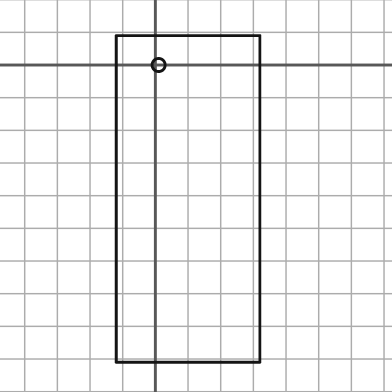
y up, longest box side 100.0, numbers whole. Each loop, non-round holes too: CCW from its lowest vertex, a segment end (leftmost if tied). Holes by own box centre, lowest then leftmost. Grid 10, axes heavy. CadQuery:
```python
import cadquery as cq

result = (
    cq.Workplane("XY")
    .moveTo(-12.0, -91.0)
    .lineTo(32.0, -91.0)
    .lineTo(32.0, 9.0)
    .lineTo(-12.0, 9.0)
    .close()
    .moveTo(1.0, 0.0)
    .circle(2.0)
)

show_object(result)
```